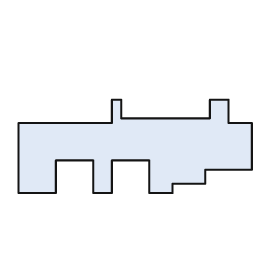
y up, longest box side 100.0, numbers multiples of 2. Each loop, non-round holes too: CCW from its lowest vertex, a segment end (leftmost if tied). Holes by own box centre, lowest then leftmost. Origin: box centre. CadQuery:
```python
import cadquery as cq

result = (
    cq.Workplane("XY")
    .moveTo(-50.0, -20.0)
    .lineTo(-34.0, -20.0)
    .lineTo(-34.0, -6.0)
    .lineTo(-18.0, -6.0)
    .lineTo(-18.0, -20.0)
    .lineTo(-10.0, -20.0)
    .lineTo(-10.0, -6.0)
    .lineTo(6.0, -6.0)
    .lineTo(6.0, -20.0)
    .lineTo(16.0, -20.0)
    .lineTo(16.0, -16.0)
    .lineTo(30.0, -16.0)
    .lineTo(30.0, -10.0)
    .lineTo(50.0, -10.0)
    .lineTo(50.0, 10.0)
    .lineTo(40.0, 10.0)
    .lineTo(40.0, 20.0)
    .lineTo(32.0, 20.0)
    .lineTo(32.0, 12.0)
    .lineTo(-6.0, 12.0)
    .lineTo(-6.0, 20.0)
    .lineTo(-10.0, 20.0)
    .lineTo(-10.0, 10.0)
    .lineTo(-50.0, 10.0)
    .close()
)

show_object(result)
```